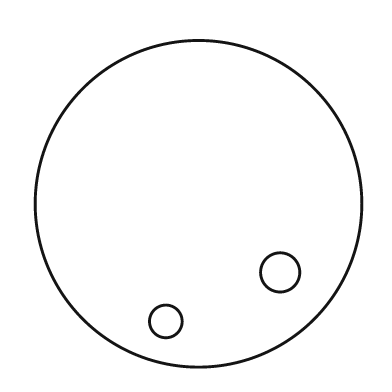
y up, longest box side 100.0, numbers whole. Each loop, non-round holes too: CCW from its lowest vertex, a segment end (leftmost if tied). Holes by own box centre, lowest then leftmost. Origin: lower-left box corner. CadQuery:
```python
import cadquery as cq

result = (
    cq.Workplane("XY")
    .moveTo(50.0, 50.0)
    .circle(50.0)
    .moveTo(40.0, 14.0)
    .circle(5.0)
    .moveTo(75.0, 29.0)
    .circle(6.0)
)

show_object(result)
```